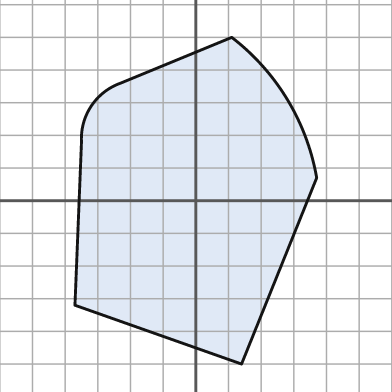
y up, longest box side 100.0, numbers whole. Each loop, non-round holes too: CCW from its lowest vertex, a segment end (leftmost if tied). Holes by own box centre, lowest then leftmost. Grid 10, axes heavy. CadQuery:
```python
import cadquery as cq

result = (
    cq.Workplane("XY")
    .moveTo(14.0, -50.0)
    .lineTo(37.0, 7.0)
    .threePointArc((28.0, 31.0), (11.0, 50.0))
    .lineTo(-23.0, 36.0)
    .threePointArc((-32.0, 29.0), (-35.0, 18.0))
    .lineTo(-37.0, -32.0)
    .close()
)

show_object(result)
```